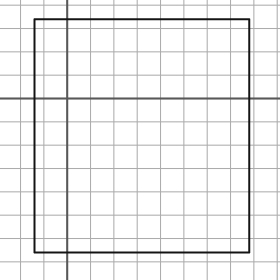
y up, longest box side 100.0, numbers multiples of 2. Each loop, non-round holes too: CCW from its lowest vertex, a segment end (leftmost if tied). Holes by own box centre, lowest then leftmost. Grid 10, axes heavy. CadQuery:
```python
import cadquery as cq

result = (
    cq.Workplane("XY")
    .moveTo(-14.0, -66.0)
    .lineTo(78.0, -66.0)
    .lineTo(78.0, 34.0)
    .lineTo(-14.0, 34.0)
    .close()
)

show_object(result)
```